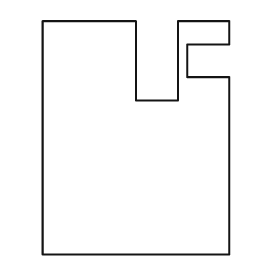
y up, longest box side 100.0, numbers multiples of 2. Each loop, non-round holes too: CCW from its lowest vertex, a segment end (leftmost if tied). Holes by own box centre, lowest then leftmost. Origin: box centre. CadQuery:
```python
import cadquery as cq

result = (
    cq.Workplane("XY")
    .moveTo(-40.0, -50.0)
    .lineTo(40.0, -50.0)
    .lineTo(40.0, 26.0)
    .lineTo(22.0, 26.0)
    .lineTo(22.0, 40.0)
    .lineTo(40.0, 40.0)
    .lineTo(40.0, 50.0)
    .lineTo(18.0, 50.0)
    .lineTo(18.0, 16.0)
    .lineTo(0.0, 16.0)
    .lineTo(0.0, 50.0)
    .lineTo(-40.0, 50.0)
    .close()
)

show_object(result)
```